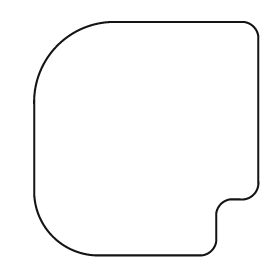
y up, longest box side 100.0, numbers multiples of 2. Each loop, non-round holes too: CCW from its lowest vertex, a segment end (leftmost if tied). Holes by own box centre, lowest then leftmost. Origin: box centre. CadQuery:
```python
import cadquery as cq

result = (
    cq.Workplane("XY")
    .moveTo(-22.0, -50.0)
    .lineTo(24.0, -50.0)
    .threePointArc((28.0, -48.0), (30.0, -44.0))
    .lineTo(30.0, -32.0)
    .threePointArc((32.0, -28.0), (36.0, -26.0))
    .lineTo(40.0, -26.0)
    .threePointArc((46.0, -24.0), (48.0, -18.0))
    .lineTo(48.0, 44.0)
    .threePointArc((46.0, 48.0), (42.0, 50.0))
    .lineTo(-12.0, 50.0)
    .threePointArc((-38.0, 40.0), (-48.0, 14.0))
    .lineTo(-48.0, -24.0)
    .threePointArc((-40.0, -42.0), (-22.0, -50.0))
    .close()
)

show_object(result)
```